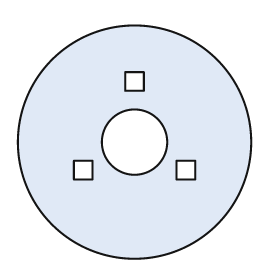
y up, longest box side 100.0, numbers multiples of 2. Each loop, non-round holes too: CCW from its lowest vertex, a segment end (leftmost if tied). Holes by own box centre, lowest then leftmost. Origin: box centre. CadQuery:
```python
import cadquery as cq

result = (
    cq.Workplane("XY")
    .moveTo(0.0, 0.0)
    .circle(50.0)
    .moveTo(-26.0, -16.0)
    .lineTo(-18.0, -16.0)
    .lineTo(-18.0, -8.0)
    .lineTo(-26.0, -8.0)
    .close()
    .moveTo(18.0, -16.0)
    .lineTo(26.0, -16.0)
    .lineTo(26.0, -8.0)
    .lineTo(18.0, -8.0)
    .close()
    .moveTo(0.0, 0.0)
    .circle(14.0)
    .moveTo(-4.0, 22.0)
    .lineTo(4.0, 22.0)
    .lineTo(4.0, 30.0)
    .lineTo(-4.0, 30.0)
    .close()
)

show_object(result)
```